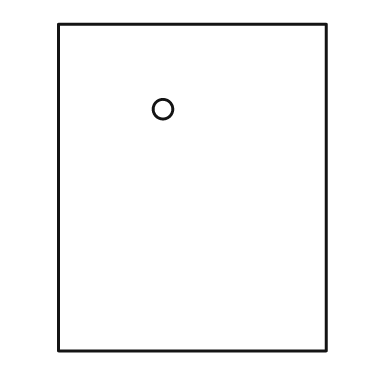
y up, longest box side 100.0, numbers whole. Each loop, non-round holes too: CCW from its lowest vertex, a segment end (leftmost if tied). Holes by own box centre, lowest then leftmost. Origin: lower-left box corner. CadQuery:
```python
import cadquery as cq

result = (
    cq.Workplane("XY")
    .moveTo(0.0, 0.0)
    .lineTo(82.0, 0.0)
    .lineTo(82.0, 100.0)
    .lineTo(0.0, 100.0)
    .close()
    .moveTo(32.0, 74.0)
    .circle(3.0)
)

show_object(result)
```